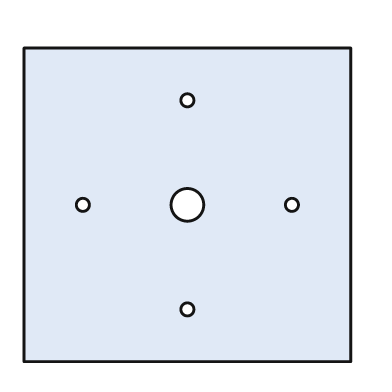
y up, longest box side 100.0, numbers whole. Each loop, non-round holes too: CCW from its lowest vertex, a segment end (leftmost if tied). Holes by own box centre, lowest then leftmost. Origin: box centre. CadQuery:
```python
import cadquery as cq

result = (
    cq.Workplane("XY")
    .moveTo(-50.0, -48.0)
    .lineTo(50.0, -48.0)
    .lineTo(50.0, 48.0)
    .lineTo(-50.0, 48.0)
    .close()
    .moveTo(0.0, -32.0)
    .circle(2.0)
    .moveTo(-32.0, 0.0)
    .circle(2.0)
    .moveTo(0.0, 0.0)
    .circle(5.0)
    .moveTo(32.0, 0.0)
    .circle(2.0)
    .moveTo(0.0, 32.0)
    .circle(2.0)
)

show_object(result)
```